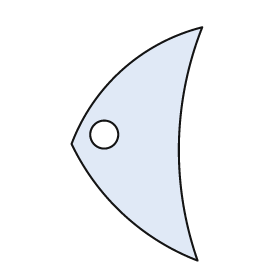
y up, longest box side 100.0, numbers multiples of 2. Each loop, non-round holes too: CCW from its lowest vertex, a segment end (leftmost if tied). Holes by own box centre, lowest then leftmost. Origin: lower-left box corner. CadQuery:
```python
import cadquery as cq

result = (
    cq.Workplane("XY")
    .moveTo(54.0, 0.0)
    .threePointArc((46.0, 50.0), (56.0, 100.0))
    .threePointArc((22.0, 82.0), (0.0, 50.0))
    .threePointArc((22.0, 20.0), (54.0, 0.0))
    .close()
    .moveTo(14.0, 54.0)
    .circle(6.0)
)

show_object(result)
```